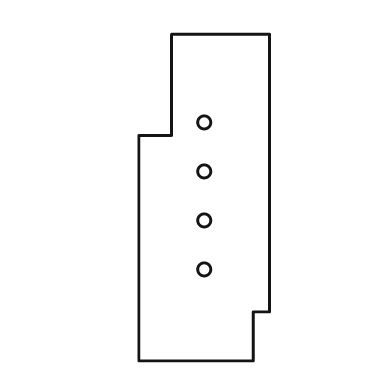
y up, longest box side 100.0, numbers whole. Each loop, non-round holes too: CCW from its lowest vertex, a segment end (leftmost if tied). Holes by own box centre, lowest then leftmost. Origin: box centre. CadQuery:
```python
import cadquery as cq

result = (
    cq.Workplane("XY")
    .moveTo(-20.0, -50.0)
    .lineTo(15.0, -50.0)
    .lineTo(15.0, -35.0)
    .lineTo(20.0, -35.0)
    .lineTo(20.0, 50.0)
    .lineTo(-10.0, 50.0)
    .lineTo(-10.0, 19.0)
    .lineTo(-20.0, 19.0)
    .close()
    .moveTo(0.0, -22.0)
    .circle(2.0)
    .moveTo(0.0, -7.0)
    .circle(2.0)
    .moveTo(0.0, 8.0)
    .circle(2.0)
    .moveTo(0.0, 23.0)
    .circle(2.0)
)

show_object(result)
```